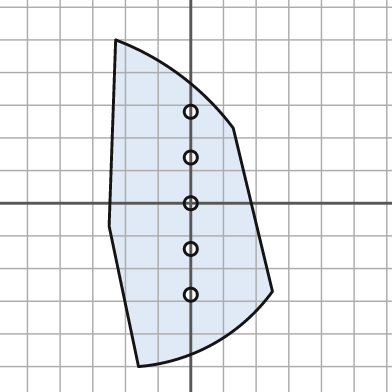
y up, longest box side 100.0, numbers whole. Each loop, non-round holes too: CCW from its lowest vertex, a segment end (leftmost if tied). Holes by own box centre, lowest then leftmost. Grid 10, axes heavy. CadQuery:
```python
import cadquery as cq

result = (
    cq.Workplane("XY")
    .moveTo(-16.0, -50.0)
    .threePointArc((7.0, -43.0), (25.0, -27.0))
    .lineTo(13.0, 23.0)
    .threePointArc((-3.0, 39.0), (-23.0, 50.0))
    .lineTo(-25.0, -7.0)
    .close()
    .moveTo(0.0, -28.0)
    .circle(2.0)
    .moveTo(0.0, -14.0)
    .circle(2.0)
    .moveTo(0.0, 0.0)
    .circle(2.0)
    .moveTo(0.0, 14.0)
    .circle(2.0)
    .moveTo(0.0, 28.0)
    .circle(2.0)
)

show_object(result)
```